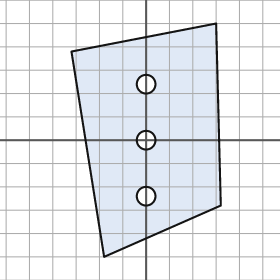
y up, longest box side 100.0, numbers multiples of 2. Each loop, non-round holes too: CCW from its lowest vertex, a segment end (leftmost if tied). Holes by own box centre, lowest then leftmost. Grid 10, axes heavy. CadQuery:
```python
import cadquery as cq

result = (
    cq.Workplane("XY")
    .moveTo(-18.0, -50.0)
    .lineTo(32.0, -28.0)
    .lineTo(30.0, 50.0)
    .lineTo(-32.0, 38.0)
    .close()
    .moveTo(0.0, -24.0)
    .circle(4.0)
    .moveTo(0.0, 0.0)
    .circle(4.0)
    .moveTo(0.0, 24.0)
    .circle(4.0)
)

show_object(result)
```